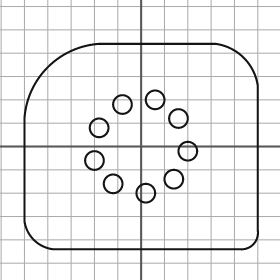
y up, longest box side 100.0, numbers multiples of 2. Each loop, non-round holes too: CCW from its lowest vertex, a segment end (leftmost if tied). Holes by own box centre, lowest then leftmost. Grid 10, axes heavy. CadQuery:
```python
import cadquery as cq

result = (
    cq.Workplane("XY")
    .moveTo(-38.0, -44.0)
    .lineTo(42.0, -44.0)
    .threePointArc((48.0, -42.0), (50.0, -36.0))
    .lineTo(50.0, 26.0)
    .threePointArc((44.0, 38.0), (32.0, 44.0))
    .lineTo(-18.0, 44.0)
    .threePointArc((-40.0, 34.0), (-50.0, 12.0))
    .lineTo(-50.0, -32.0)
    .threePointArc((-46.0, -40.0), (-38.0, -44.0))
    .close()
    .moveTo(2.0, -20.0)
    .circle(4.0)
    .moveTo(-12.0, -16.0)
    .circle(4.0)
    .moveTo(14.0, -14.0)
    .circle(4.0)
    .moveTo(-20.0, -6.0)
    .circle(4.0)
    .moveTo(20.0, -2.0)
    .circle(4.0)
    .moveTo(-18.0, 8.0)
    .circle(4.0)
    .moveTo(16.0, 12.0)
    .circle(4.0)
    .moveTo(-8.0, 18.0)
    .circle(4.0)
    .moveTo(6.0, 20.0)
    .circle(4.0)
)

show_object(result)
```